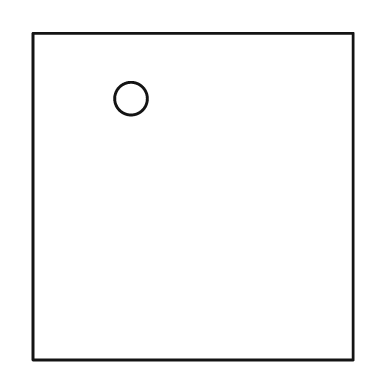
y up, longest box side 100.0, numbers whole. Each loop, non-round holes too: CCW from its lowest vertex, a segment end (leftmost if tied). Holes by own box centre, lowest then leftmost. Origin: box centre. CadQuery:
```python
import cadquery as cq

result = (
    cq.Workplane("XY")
    .moveTo(-49.0, -50.0)
    .lineTo(49.0, -50.0)
    .lineTo(49.0, 50.0)
    .lineTo(-49.0, 50.0)
    .close()
    .moveTo(-19.0, 30.0)
    .circle(5.0)
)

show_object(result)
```